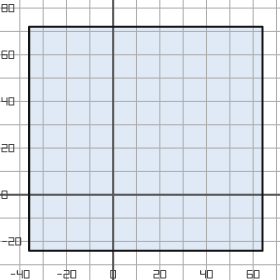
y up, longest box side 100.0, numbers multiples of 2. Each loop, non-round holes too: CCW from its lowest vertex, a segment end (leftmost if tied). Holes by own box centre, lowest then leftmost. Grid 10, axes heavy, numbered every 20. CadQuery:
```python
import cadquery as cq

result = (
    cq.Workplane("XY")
    .moveTo(-36.0, -24.0)
    .lineTo(64.0, -24.0)
    .lineTo(64.0, 72.0)
    .lineTo(-36.0, 72.0)
    .close()
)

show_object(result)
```